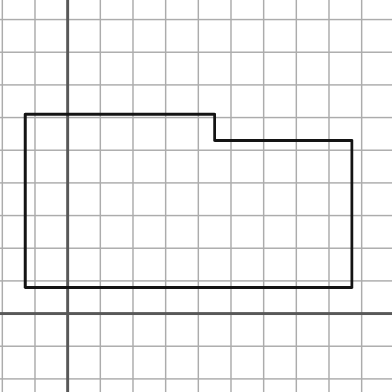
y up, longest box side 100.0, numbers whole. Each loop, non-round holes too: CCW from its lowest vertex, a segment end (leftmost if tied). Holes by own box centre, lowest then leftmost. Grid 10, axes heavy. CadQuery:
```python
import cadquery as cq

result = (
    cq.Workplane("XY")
    .moveTo(-13.0, 8.0)
    .lineTo(87.0, 8.0)
    .lineTo(87.0, 53.0)
    .lineTo(45.0, 53.0)
    .lineTo(45.0, 61.0)
    .lineTo(-13.0, 61.0)
    .close()
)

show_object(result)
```